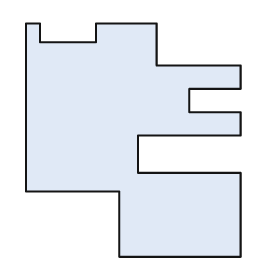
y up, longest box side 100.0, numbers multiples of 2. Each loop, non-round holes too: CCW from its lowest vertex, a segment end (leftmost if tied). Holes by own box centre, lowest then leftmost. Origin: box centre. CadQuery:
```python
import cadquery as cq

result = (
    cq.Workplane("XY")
    .moveTo(-6.0, -50.0)
    .lineTo(46.0, -50.0)
    .lineTo(46.0, -14.0)
    .lineTo(2.0, -14.0)
    .lineTo(2.0, 2.0)
    .lineTo(46.0, 2.0)
    .lineTo(46.0, 12.0)
    .lineTo(24.0, 12.0)
    .lineTo(24.0, 22.0)
    .lineTo(46.0, 22.0)
    .lineTo(46.0, 32.0)
    .lineTo(10.0, 32.0)
    .lineTo(10.0, 50.0)
    .lineTo(-16.0, 50.0)
    .lineTo(-16.0, 42.0)
    .lineTo(-40.0, 42.0)
    .lineTo(-40.0, 50.0)
    .lineTo(-46.0, 50.0)
    .lineTo(-46.0, -22.0)
    .lineTo(-6.0, -22.0)
    .close()
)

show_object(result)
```